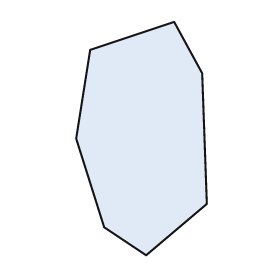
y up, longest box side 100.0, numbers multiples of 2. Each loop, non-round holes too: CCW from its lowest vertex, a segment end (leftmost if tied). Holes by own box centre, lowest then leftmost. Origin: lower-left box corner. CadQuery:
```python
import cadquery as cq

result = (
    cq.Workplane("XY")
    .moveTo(30.0, 0.0)
    .lineTo(56.0, 22.0)
    .lineTo(54.0, 78.0)
    .lineTo(42.0, 100.0)
    .lineTo(6.0, 88.0)
    .lineTo(0.0, 50.0)
    .lineTo(12.0, 12.0)
    .close()
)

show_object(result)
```